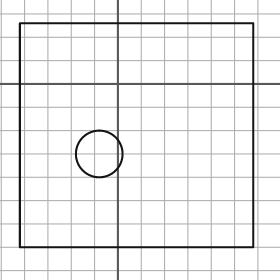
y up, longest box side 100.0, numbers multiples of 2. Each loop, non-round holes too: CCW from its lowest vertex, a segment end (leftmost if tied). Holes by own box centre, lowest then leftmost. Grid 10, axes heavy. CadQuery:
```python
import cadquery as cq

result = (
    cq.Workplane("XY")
    .moveTo(-42.0, -70.0)
    .lineTo(58.0, -70.0)
    .lineTo(58.0, 26.0)
    .lineTo(-42.0, 26.0)
    .close()
    .moveTo(-8.0, -30.0)
    .circle(10.0)
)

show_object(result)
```